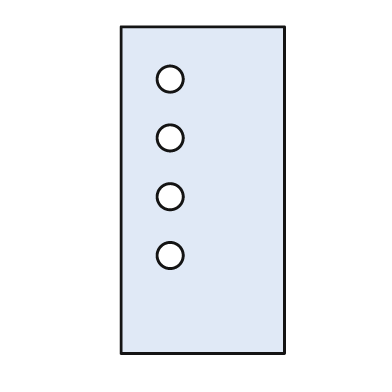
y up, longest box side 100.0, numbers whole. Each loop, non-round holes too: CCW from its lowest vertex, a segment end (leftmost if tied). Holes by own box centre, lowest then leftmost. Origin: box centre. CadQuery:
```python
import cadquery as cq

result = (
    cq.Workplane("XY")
    .moveTo(-25.0, -50.0)
    .lineTo(25.0, -50.0)
    .lineTo(25.0, 50.0)
    .lineTo(-25.0, 50.0)
    .close()
    .moveTo(-10.0, -20.0)
    .circle(4.0)
    .moveTo(-10.0, -2.0)
    .circle(4.0)
    .moveTo(-10.0, 16.0)
    .circle(4.0)
    .moveTo(-10.0, 34.0)
    .circle(4.0)
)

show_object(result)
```